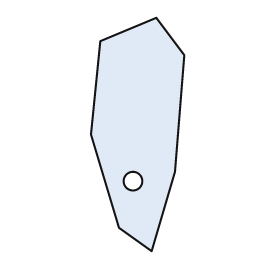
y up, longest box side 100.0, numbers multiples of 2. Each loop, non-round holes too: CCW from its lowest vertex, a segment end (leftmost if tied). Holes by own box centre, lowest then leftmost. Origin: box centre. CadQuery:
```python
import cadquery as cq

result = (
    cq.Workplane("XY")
    .moveTo(6.0, -50.0)
    .lineTo(16.0, -16.0)
    .lineTo(20.0, 34.0)
    .lineTo(8.0, 50.0)
    .lineTo(-16.0, 40.0)
    .lineTo(-20.0, 0.0)
    .lineTo(-8.0, -40.0)
    .close()
    .moveTo(-2.0, -20.0)
    .circle(4.0)
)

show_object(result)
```